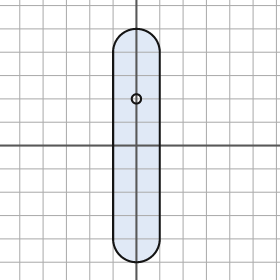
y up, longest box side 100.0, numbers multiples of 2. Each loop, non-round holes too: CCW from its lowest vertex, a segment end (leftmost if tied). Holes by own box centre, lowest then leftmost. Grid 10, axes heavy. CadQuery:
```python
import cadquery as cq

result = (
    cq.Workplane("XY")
    .moveTo(-10.0, -40.0)
    .threePointArc((0.0, -50.0), (10.0, -40.0))
    .lineTo(10.0, 40.0)
    .threePointArc((0.0, 50.0), (-10.0, 40.0))
    .close()
    .moveTo(0.0, 20.0)
    .circle(2.0)
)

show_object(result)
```